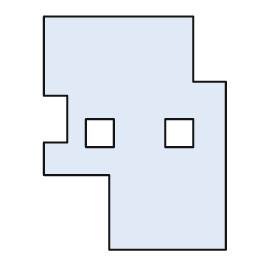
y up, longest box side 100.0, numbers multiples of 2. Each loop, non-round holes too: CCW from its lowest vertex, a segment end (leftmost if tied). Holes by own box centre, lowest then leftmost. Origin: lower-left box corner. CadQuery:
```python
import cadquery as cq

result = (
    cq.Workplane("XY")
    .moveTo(28.0, 0.0)
    .lineTo(78.0, 0.0)
    .lineTo(78.0, 72.0)
    .lineTo(64.0, 72.0)
    .lineTo(64.0, 100.0)
    .lineTo(0.0, 100.0)
    .lineTo(0.0, 66.0)
    .lineTo(10.0, 66.0)
    .lineTo(10.0, 46.0)
    .lineTo(0.0, 46.0)
    .lineTo(0.0, 32.0)
    .lineTo(28.0, 32.0)
    .close()
    .moveTo(18.0, 44.0)
    .lineTo(30.0, 44.0)
    .lineTo(30.0, 56.0)
    .lineTo(18.0, 56.0)
    .close()
    .moveTo(52.0, 44.0)
    .lineTo(64.0, 44.0)
    .lineTo(64.0, 56.0)
    .lineTo(52.0, 56.0)
    .close()
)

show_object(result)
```